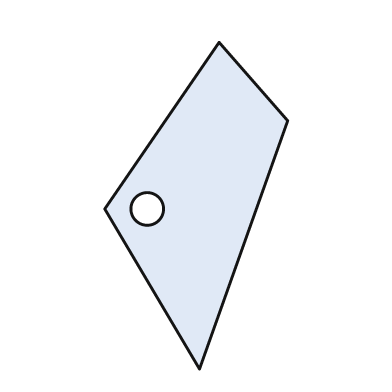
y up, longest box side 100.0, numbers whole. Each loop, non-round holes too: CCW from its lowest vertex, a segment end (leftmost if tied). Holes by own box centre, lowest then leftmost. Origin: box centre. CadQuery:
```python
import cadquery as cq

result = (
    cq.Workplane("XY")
    .moveTo(1.0, -50.0)
    .lineTo(28.0, 26.0)
    .lineTo(7.0, 50.0)
    .lineTo(-28.0, -1.0)
    .close()
    .moveTo(-15.0, -1.0)
    .circle(5.0)
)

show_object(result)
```